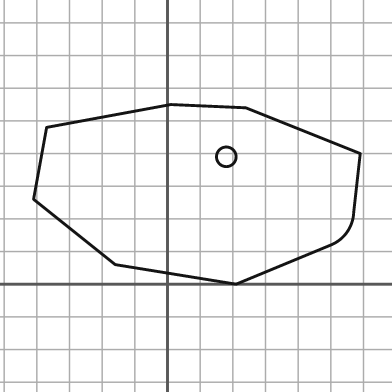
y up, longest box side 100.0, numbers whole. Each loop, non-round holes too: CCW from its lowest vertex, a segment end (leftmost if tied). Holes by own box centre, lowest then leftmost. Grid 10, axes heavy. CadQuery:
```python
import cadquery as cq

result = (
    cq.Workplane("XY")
    .moveTo(21.0, 0.0)
    .lineTo(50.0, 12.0)
    .threePointArc((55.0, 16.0), (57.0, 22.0))
    .lineTo(59.0, 40.0)
    .lineTo(24.0, 54.0)
    .lineTo(1.0, 55.0)
    .lineTo(-37.0, 48.0)
    .lineTo(-41.0, 26.0)
    .lineTo(-16.0, 6.0)
    .close()
    .moveTo(18.0, 39.0)
    .circle(3.0)
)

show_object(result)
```